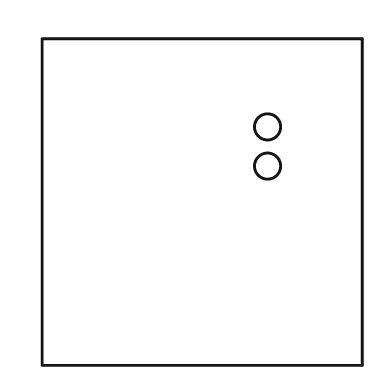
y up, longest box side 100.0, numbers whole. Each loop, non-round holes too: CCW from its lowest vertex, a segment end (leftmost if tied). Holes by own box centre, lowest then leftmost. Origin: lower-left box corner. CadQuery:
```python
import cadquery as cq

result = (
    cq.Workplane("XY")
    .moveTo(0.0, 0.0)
    .lineTo(98.0, 0.0)
    .lineTo(98.0, 100.0)
    .lineTo(0.0, 100.0)
    .close()
    .moveTo(69.0, 61.0)
    .circle(4.0)
    .moveTo(69.0, 73.0)
    .circle(4.0)
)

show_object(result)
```